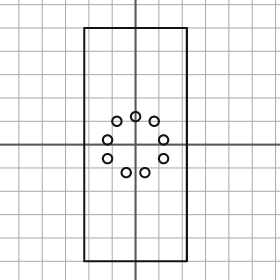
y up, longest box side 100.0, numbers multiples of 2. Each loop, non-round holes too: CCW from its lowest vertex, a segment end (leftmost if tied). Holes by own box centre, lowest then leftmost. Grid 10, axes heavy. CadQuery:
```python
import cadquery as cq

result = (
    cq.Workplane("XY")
    .moveTo(-22.0, -50.0)
    .lineTo(22.0, -50.0)
    .lineTo(22.0, 50.0)
    .lineTo(-22.0, 50.0)
    .close()
    .moveTo(-4.0, -12.0)
    .circle(2.0)
    .moveTo(4.0, -12.0)
    .circle(2.0)
    .moveTo(-12.0, -6.0)
    .circle(2.0)
    .moveTo(12.0, -6.0)
    .circle(2.0)
    .moveTo(-12.0, 2.0)
    .circle(2.0)
    .moveTo(12.0, 2.0)
    .circle(2.0)
    .moveTo(-8.0, 10.0)
    .circle(2.0)
    .moveTo(8.0, 10.0)
    .circle(2.0)
    .moveTo(0.0, 12.0)
    .circle(2.0)
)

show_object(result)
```